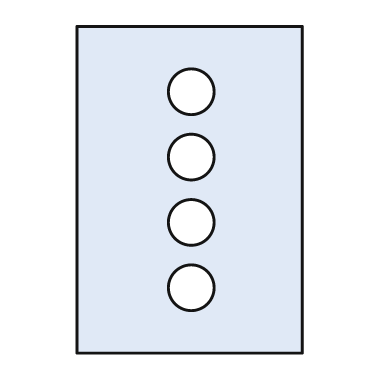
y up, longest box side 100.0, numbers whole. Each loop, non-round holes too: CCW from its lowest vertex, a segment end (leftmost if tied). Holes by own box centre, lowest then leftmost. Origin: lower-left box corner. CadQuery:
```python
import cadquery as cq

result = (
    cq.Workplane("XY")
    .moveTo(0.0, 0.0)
    .lineTo(69.0, 0.0)
    .lineTo(69.0, 100.0)
    .lineTo(0.0, 100.0)
    .close()
    .moveTo(35.0, 20.0)
    .circle(7.0)
    .moveTo(35.0, 40.0)
    .circle(7.0)
    .moveTo(35.0, 60.0)
    .circle(7.0)
    .moveTo(35.0, 80.0)
    .circle(7.0)
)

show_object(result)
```